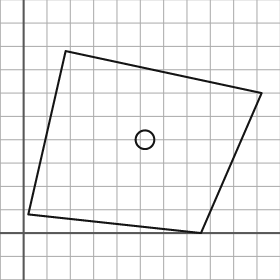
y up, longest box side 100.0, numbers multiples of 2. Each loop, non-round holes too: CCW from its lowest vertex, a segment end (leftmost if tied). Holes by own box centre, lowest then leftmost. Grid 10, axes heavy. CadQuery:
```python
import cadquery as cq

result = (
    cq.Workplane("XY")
    .moveTo(76.0, 0.0)
    .lineTo(102.0, 60.0)
    .lineTo(18.0, 78.0)
    .lineTo(2.0, 8.0)
    .close()
    .moveTo(52.0, 40.0)
    .circle(4.0)
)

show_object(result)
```